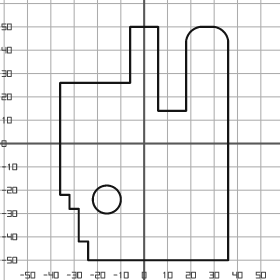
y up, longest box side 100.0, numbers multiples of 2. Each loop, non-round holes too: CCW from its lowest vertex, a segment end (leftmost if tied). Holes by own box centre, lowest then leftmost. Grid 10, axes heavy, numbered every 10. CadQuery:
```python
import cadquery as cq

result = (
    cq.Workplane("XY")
    .moveTo(-24.0, -50.0)
    .lineTo(36.0, -50.0)
    .lineTo(36.0, 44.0)
    .threePointArc((34.0, 48.0), (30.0, 50.0))
    .lineTo(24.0, 50.0)
    .threePointArc((20.0, 48.0), (18.0, 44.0))
    .lineTo(18.0, 14.0)
    .lineTo(6.0, 14.0)
    .lineTo(6.0, 50.0)
    .lineTo(-6.0, 50.0)
    .lineTo(-6.0, 26.0)
    .lineTo(-36.0, 26.0)
    .lineTo(-36.0, -22.0)
    .lineTo(-32.0, -22.0)
    .lineTo(-32.0, -28.0)
    .lineTo(-28.0, -28.0)
    .lineTo(-28.0, -42.0)
    .lineTo(-24.0, -42.0)
    .close()
    .moveTo(-16.0, -24.0)
    .circle(6.0)
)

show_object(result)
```